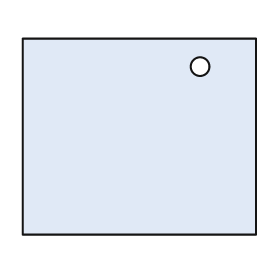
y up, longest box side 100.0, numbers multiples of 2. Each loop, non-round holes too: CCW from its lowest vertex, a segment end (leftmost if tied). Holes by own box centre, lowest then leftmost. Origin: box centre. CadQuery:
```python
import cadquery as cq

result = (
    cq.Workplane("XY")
    .moveTo(-50.0, -42.0)
    .lineTo(50.0, -42.0)
    .lineTo(50.0, 42.0)
    .lineTo(-50.0, 42.0)
    .close()
    .moveTo(26.0, 30.0)
    .circle(4.0)
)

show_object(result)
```